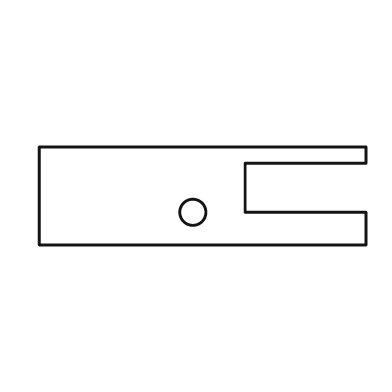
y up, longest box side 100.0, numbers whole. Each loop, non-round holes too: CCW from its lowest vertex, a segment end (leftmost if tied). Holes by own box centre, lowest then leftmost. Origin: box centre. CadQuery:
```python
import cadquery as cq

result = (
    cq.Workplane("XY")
    .moveTo(-50.0, -15.0)
    .lineTo(50.0, -15.0)
    .lineTo(50.0, -5.0)
    .lineTo(13.0, -5.0)
    .lineTo(13.0, 10.0)
    .lineTo(50.0, 10.0)
    .lineTo(50.0, 15.0)
    .lineTo(-50.0, 15.0)
    .close()
    .moveTo(-3.0, -5.0)
    .circle(4.0)
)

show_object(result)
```